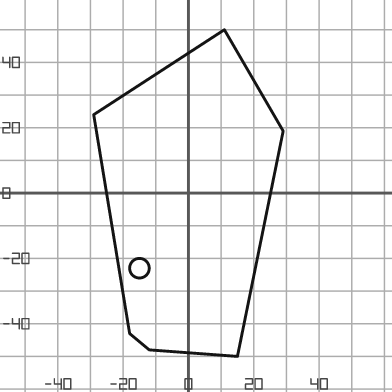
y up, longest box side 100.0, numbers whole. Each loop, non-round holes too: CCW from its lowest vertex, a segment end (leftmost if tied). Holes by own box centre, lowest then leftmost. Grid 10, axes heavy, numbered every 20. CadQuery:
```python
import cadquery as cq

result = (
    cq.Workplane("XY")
    .moveTo(15.0, -50.0)
    .lineTo(29.0, 19.0)
    .lineTo(11.0, 50.0)
    .lineTo(-29.0, 24.0)
    .lineTo(-18.0, -43.0)
    .lineTo(-12.0, -48.0)
    .close()
    .moveTo(-15.0, -23.0)
    .circle(3.0)
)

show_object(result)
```